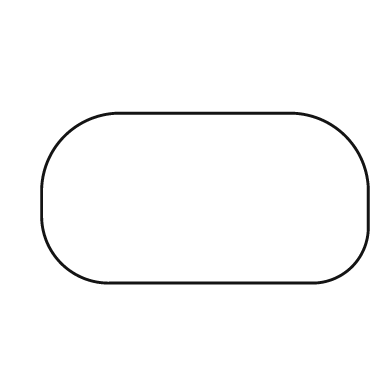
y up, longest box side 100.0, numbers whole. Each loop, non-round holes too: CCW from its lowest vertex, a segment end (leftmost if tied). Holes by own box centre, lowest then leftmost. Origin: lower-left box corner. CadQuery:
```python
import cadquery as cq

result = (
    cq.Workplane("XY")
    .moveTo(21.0, 0.0)
    .lineTo(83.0, 0.0)
    .threePointArc((95.0, 5.0), (100.0, 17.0))
    .lineTo(100.0, 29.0)
    .threePointArc((93.0, 45.0), (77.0, 52.0))
    .lineTo(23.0, 52.0)
    .threePointArc((7.0, 45.0), (0.0, 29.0))
    .lineTo(0.0, 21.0)
    .threePointArc((6.0, 6.0), (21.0, 0.0))
    .close()
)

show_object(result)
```